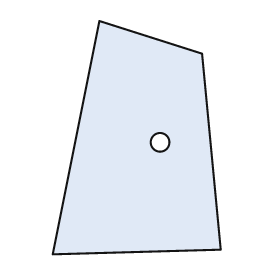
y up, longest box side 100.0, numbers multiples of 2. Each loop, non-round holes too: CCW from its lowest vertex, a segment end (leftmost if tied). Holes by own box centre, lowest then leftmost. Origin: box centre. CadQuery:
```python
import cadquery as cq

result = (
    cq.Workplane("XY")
    .moveTo(-36.0, -50.0)
    .lineTo(36.0, -48.0)
    .lineTo(28.0, 36.0)
    .lineTo(-16.0, 50.0)
    .close()
    .moveTo(10.0, -2.0)
    .circle(4.0)
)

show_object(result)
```